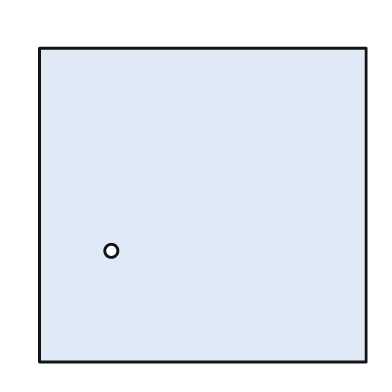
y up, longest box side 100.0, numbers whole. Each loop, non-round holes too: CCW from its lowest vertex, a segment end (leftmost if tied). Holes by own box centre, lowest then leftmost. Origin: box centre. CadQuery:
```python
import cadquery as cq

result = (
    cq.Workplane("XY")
    .moveTo(-50.0, -48.0)
    .lineTo(50.0, -48.0)
    .lineTo(50.0, 48.0)
    .lineTo(-50.0, 48.0)
    .close()
    .moveTo(-28.0, -14.0)
    .circle(2.0)
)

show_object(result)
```